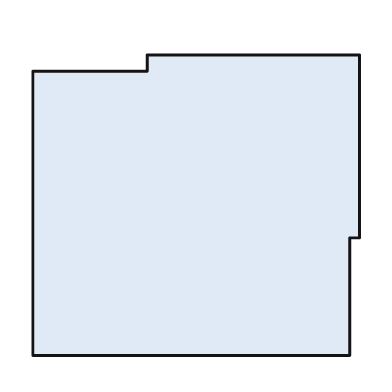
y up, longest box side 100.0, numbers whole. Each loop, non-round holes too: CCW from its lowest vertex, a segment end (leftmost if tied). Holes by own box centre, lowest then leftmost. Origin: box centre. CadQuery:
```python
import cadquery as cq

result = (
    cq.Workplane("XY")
    .moveTo(-50.0, -46.0)
    .lineTo(47.0, -46.0)
    .lineTo(47.0, -10.0)
    .lineTo(50.0, -10.0)
    .lineTo(50.0, 46.0)
    .lineTo(-15.0, 46.0)
    .lineTo(-15.0, 41.0)
    .lineTo(-50.0, 41.0)
    .close()
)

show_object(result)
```